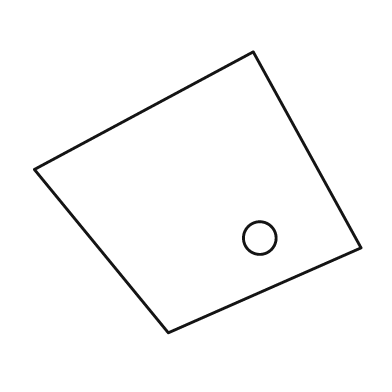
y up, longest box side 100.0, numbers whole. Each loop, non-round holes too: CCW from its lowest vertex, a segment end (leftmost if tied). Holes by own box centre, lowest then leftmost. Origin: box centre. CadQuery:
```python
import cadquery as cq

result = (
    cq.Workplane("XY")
    .moveTo(-9.0, -43.0)
    .lineTo(50.0, -17.0)
    .lineTo(17.0, 43.0)
    .lineTo(-50.0, 7.0)
    .close()
    .moveTo(19.0, -14.0)
    .circle(5.0)
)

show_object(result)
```